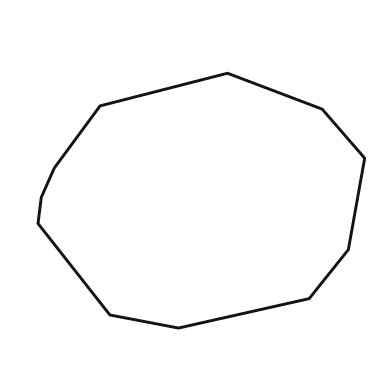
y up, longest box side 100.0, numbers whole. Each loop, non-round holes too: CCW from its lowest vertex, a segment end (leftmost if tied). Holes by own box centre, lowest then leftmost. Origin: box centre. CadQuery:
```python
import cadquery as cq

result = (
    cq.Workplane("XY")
    .moveTo(-7.0, -39.0)
    .lineTo(33.0, -30.0)
    .lineTo(45.0, -15.0)
    .lineTo(50.0, 13.0)
    .lineTo(37.0, 28.0)
    .lineTo(8.0, 39.0)
    .lineTo(-31.0, 29.0)
    .lineTo(-45.0, 10.0)
    .lineTo(-49.0, 1.0)
    .lineTo(-50.0, -7.0)
    .lineTo(-28.0, -35.0)
    .close()
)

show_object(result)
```